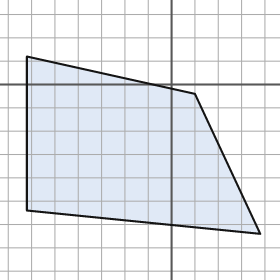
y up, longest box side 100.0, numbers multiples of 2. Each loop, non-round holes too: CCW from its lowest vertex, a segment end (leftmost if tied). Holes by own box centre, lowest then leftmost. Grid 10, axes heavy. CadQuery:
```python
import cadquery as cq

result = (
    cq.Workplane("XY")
    .moveTo(38.0, -64.0)
    .lineTo(10.0, -4.0)
    .lineTo(-62.0, 12.0)
    .lineTo(-62.0, -54.0)
    .close()
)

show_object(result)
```